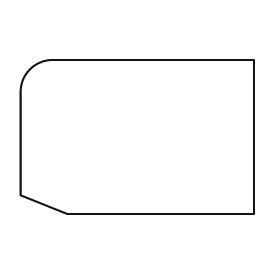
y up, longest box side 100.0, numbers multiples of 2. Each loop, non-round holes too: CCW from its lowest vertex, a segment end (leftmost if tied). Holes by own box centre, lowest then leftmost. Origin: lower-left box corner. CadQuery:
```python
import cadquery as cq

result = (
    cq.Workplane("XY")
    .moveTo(20.0, 0.0)
    .lineTo(100.0, 0.0)
    .lineTo(100.0, 66.0)
    .lineTo(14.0, 66.0)
    .threePointArc((4.0, 62.0), (0.0, 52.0))
    .lineTo(0.0, 8.0)
    .close()
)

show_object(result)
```